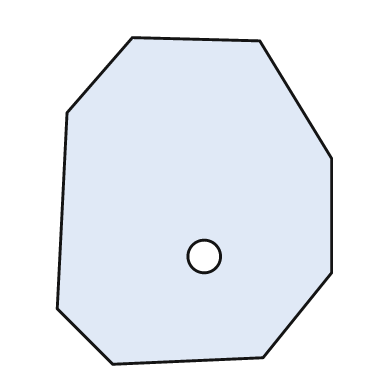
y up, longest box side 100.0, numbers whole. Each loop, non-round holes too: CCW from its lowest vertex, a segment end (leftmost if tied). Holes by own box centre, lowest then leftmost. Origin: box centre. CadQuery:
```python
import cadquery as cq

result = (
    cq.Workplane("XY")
    .moveTo(-25.0, -50.0)
    .lineTo(21.0, -48.0)
    .lineTo(42.0, -22.0)
    .lineTo(42.0, 13.0)
    .lineTo(20.0, 49.0)
    .lineTo(-19.0, 50.0)
    .lineTo(-39.0, 27.0)
    .lineTo(-42.0, -33.0)
    .close()
    .moveTo(3.0, -17.0)
    .circle(5.0)
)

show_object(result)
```